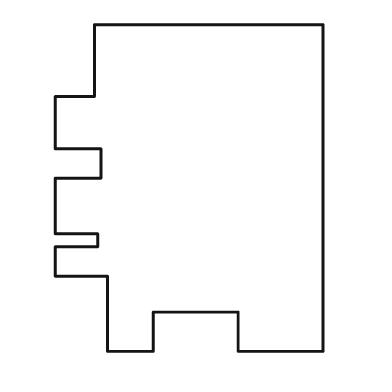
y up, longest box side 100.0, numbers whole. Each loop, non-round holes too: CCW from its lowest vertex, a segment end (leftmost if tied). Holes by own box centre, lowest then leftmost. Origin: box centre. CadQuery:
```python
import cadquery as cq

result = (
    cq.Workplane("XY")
    .moveTo(-25.0, -50.0)
    .lineTo(-11.0, -50.0)
    .lineTo(-11.0, -38.0)
    .lineTo(15.0, -38.0)
    .lineTo(15.0, -50.0)
    .lineTo(41.0, -50.0)
    .lineTo(41.0, 50.0)
    .lineTo(-29.0, 50.0)
    .lineTo(-29.0, 28.0)
    .lineTo(-41.0, 28.0)
    .lineTo(-41.0, 12.0)
    .lineTo(-27.0, 12.0)
    .lineTo(-27.0, 3.0)
    .lineTo(-41.0, 3.0)
    .lineTo(-41.0, -14.0)
    .lineTo(-28.0, -14.0)
    .lineTo(-28.0, -18.0)
    .lineTo(-41.0, -18.0)
    .lineTo(-41.0, -27.0)
    .lineTo(-25.0, -27.0)
    .close()
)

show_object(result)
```